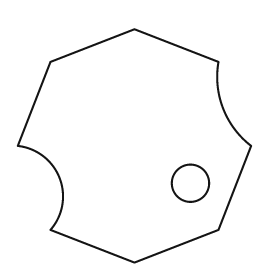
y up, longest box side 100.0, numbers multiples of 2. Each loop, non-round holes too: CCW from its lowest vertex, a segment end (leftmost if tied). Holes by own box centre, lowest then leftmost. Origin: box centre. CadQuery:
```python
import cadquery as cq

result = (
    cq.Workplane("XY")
    .moveTo(0.0, -50.0)
    .lineTo(36.0, -36.0)
    .lineTo(50.0, 0.0)
    .threePointArc((38.0, 16.0), (36.0, 36.0))
    .lineTo(0.0, 50.0)
    .lineTo(-36.0, 36.0)
    .lineTo(-50.0, 0.0)
    .threePointArc((-32.0, -14.0), (-36.0, -36.0))
    .close()
    .moveTo(24.0, -16.0)
    .circle(8.0)
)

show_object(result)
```